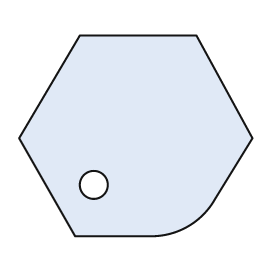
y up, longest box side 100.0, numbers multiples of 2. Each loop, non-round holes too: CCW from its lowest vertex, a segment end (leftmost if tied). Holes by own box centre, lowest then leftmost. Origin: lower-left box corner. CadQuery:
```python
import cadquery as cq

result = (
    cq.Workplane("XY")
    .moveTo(24.0, 0.0)
    .lineTo(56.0, 0.0)
    .threePointArc((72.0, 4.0), (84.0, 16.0))
    .lineTo(100.0, 42.0)
    .lineTo(76.0, 86.0)
    .lineTo(26.0, 86.0)
    .lineTo(0.0, 42.0)
    .close()
    .moveTo(32.0, 22.0)
    .circle(6.0)
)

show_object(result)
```